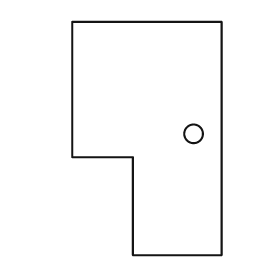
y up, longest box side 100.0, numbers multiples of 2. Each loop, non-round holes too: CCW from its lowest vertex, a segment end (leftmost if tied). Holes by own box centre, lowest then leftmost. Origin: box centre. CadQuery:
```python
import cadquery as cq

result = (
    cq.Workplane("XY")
    .moveTo(-6.0, -50.0)
    .lineTo(32.0, -50.0)
    .lineTo(32.0, 50.0)
    .lineTo(-32.0, 50.0)
    .lineTo(-32.0, -8.0)
    .lineTo(-6.0, -8.0)
    .close()
    .moveTo(20.0, 2.0)
    .circle(4.0)
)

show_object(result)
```